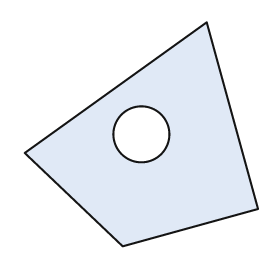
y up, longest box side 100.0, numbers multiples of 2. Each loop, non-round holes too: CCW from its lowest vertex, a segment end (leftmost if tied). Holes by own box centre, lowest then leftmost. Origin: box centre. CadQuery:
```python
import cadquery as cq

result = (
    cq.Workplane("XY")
    .moveTo(-8.0, -48.0)
    .lineTo(50.0, -32.0)
    .lineTo(28.0, 48.0)
    .lineTo(-50.0, -8.0)
    .close()
    .moveTo(0.0, 0.0)
    .circle(12.0)
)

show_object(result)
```